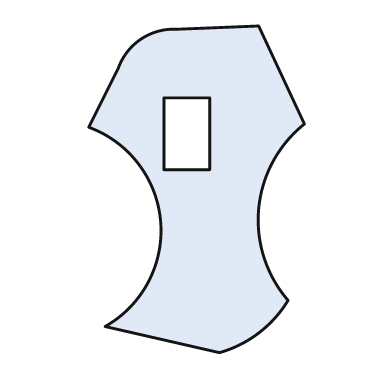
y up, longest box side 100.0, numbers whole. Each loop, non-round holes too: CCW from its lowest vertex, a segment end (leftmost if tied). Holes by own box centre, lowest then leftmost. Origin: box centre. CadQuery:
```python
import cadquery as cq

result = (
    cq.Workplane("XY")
    .moveTo(7.0, -50.0)
    .threePointArc((19.0, -44.0), (28.0, -34.0))
    .threePointArc((19.0, -6.0), (33.0, 20.0))
    .lineTo(19.0, 50.0)
    .lineTo(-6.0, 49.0)
    .threePointArc((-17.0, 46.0), (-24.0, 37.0))
    .lineTo(-33.0, 19.0)
    .threePointArc((-11.0, -10.0), (-28.0, -42.0))
    .close()
    .moveTo(-10.0, 6.0)
    .lineTo(4.0, 6.0)
    .lineTo(4.0, 28.0)
    .lineTo(-10.0, 28.0)
    .close()
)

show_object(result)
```